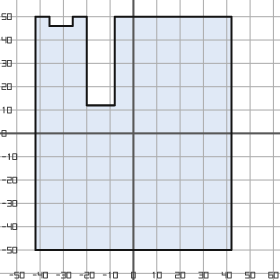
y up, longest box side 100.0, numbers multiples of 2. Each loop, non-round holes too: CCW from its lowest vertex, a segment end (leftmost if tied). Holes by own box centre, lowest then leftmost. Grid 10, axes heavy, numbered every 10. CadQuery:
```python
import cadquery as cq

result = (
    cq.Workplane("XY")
    .moveTo(-42.0, -50.0)
    .lineTo(42.0, -50.0)
    .lineTo(42.0, 50.0)
    .lineTo(-8.0, 50.0)
    .lineTo(-8.0, 12.0)
    .lineTo(-20.0, 12.0)
    .lineTo(-20.0, 50.0)
    .lineTo(-26.0, 50.0)
    .lineTo(-26.0, 46.0)
    .lineTo(-36.0, 46.0)
    .lineTo(-36.0, 50.0)
    .lineTo(-42.0, 50.0)
    .close()
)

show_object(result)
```